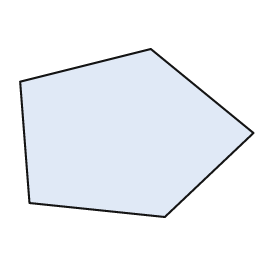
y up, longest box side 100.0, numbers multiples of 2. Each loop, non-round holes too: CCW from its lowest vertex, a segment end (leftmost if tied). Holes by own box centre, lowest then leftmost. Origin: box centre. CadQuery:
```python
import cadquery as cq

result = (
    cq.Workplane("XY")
    .moveTo(12.0, -36.0)
    .lineTo(50.0, 0.0)
    .lineTo(6.0, 36.0)
    .lineTo(-50.0, 22.0)
    .lineTo(-46.0, -30.0)
    .close()
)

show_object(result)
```